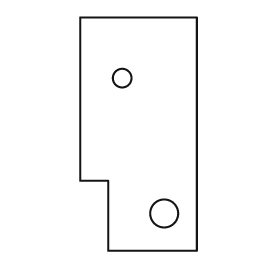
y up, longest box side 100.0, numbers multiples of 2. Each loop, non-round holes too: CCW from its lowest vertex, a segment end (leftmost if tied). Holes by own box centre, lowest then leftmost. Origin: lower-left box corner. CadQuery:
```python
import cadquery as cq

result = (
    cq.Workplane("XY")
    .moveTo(12.0, 0.0)
    .lineTo(50.0, 0.0)
    .lineTo(50.0, 100.0)
    .lineTo(0.0, 100.0)
    .lineTo(0.0, 30.0)
    .lineTo(12.0, 30.0)
    .close()
    .moveTo(36.0, 16.0)
    .circle(6.0)
    .moveTo(18.0, 74.0)
    .circle(4.0)
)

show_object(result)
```